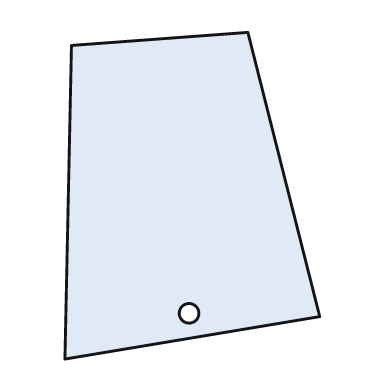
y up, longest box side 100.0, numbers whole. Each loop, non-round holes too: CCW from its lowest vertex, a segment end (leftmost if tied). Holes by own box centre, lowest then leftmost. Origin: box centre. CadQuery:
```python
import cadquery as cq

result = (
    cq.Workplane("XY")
    .moveTo(-39.0, -50.0)
    .lineTo(39.0, -37.0)
    .lineTo(17.0, 50.0)
    .lineTo(-37.0, 46.0)
    .close()
    .moveTo(-1.0, -36.0)
    .circle(3.0)
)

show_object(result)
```